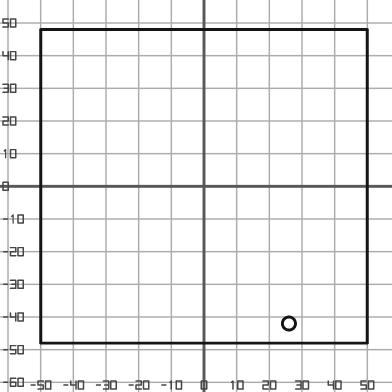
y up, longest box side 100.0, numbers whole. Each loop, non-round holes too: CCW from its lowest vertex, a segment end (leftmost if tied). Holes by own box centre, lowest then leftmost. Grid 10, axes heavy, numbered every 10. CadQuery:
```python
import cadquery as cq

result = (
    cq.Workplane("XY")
    .moveTo(-50.0, -48.0)
    .lineTo(50.0, -48.0)
    .lineTo(50.0, 48.0)
    .lineTo(-50.0, 48.0)
    .close()
    .moveTo(26.0, -42.0)
    .circle(2.0)
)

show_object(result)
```